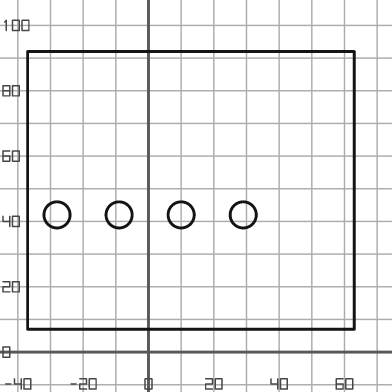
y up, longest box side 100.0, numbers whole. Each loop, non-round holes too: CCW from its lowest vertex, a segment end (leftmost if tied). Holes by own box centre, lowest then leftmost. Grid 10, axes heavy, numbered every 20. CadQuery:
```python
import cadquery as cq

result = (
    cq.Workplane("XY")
    .moveTo(-37.0, 7.0)
    .lineTo(63.0, 7.0)
    .lineTo(63.0, 92.0)
    .lineTo(-37.0, 92.0)
    .close()
    .moveTo(-28.0, 42.0)
    .circle(4.0)
    .moveTo(-9.0, 42.0)
    .circle(4.0)
    .moveTo(10.0, 42.0)
    .circle(4.0)
    .moveTo(29.0, 42.0)
    .circle(4.0)
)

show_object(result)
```